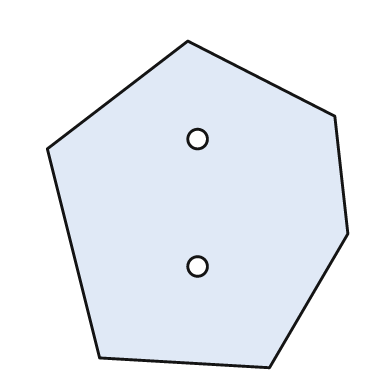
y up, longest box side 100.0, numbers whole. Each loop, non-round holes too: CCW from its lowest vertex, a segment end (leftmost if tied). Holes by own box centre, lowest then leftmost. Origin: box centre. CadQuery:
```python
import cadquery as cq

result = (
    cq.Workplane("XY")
    .moveTo(22.0, -50.0)
    .lineTo(46.0, -9.0)
    .lineTo(42.0, 27.0)
    .lineTo(-3.0, 50.0)
    .lineTo(-46.0, 17.0)
    .lineTo(-30.0, -47.0)
    .close()
    .moveTo(0.0, -19.0)
    .circle(3.0)
    .moveTo(0.0, 20.0)
    .circle(3.0)
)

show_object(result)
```